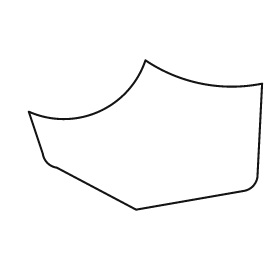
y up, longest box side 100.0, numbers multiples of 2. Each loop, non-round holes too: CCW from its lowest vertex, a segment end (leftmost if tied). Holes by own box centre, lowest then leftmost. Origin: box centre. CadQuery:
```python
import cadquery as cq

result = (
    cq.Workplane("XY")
    .moveTo(-4.0, -32.0)
    .lineTo(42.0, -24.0)
    .threePointArc((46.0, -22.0), (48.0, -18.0))
    .lineTo(50.0, 22.0)
    .threePointArc((24.0, 22.0), (0.0, 32.0))
    .threePointArc((-20.0, 10.0), (-50.0, 10.0))
    .lineTo(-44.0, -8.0)
    .threePointArc((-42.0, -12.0), (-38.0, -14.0))
    .close()
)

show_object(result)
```